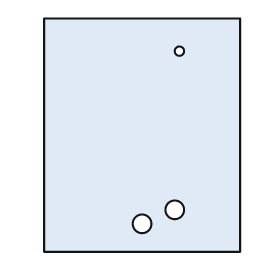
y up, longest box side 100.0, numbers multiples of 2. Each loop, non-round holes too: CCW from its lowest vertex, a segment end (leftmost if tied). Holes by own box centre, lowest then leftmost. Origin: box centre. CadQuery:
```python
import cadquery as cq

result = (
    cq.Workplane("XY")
    .moveTo(-42.0, -50.0)
    .lineTo(42.0, -50.0)
    .lineTo(42.0, 50.0)
    .lineTo(-42.0, 50.0)
    .close()
    .moveTo(0.0, -38.0)
    .circle(4.0)
    .moveTo(14.0, -32.0)
    .circle(4.0)
    .moveTo(16.0, 36.0)
    .circle(2.0)
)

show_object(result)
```